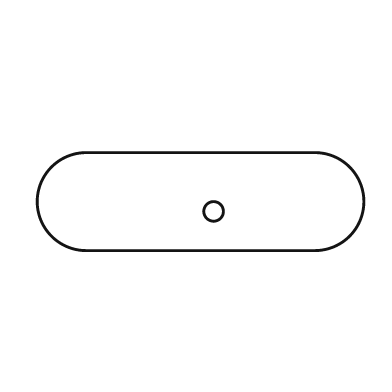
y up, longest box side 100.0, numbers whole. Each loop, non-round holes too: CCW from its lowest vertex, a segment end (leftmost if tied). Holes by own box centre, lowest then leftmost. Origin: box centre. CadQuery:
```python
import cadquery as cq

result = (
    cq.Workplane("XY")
    .moveTo(-35.0, -15.0)
    .lineTo(35.0, -15.0)
    .threePointArc((50.0, 0.0), (35.0, 15.0))
    .lineTo(-35.0, 15.0)
    .threePointArc((-50.0, 0.0), (-35.0, -15.0))
    .close()
    .moveTo(4.0, -3.0)
    .circle(3.0)
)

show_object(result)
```